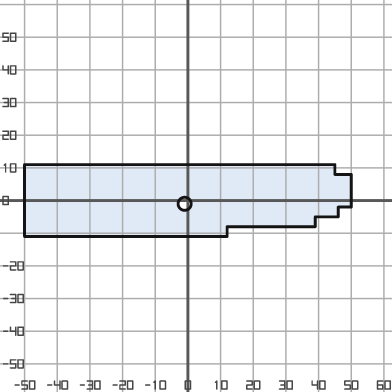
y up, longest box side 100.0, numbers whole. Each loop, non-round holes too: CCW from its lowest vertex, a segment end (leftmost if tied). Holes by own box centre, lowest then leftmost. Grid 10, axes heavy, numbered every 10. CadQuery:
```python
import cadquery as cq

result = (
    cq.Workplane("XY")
    .moveTo(-50.0, -11.0)
    .lineTo(12.0, -11.0)
    .lineTo(12.0, -8.0)
    .lineTo(39.0, -8.0)
    .lineTo(39.0, -5.0)
    .lineTo(46.0, -5.0)
    .lineTo(46.0, -2.0)
    .lineTo(50.0, -2.0)
    .lineTo(50.0, 8.0)
    .lineTo(45.0, 8.0)
    .lineTo(45.0, 11.0)
    .lineTo(-50.0, 11.0)
    .close()
    .moveTo(-1.0, -1.0)
    .circle(2.0)
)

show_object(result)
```